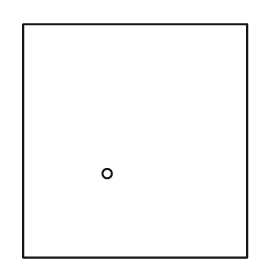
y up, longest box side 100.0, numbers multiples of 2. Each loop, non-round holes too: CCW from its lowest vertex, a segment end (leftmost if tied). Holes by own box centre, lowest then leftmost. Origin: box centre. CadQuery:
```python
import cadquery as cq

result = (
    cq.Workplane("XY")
    .moveTo(-48.0, -50.0)
    .lineTo(48.0, -50.0)
    .lineTo(48.0, 50.0)
    .lineTo(-48.0, 50.0)
    .close()
    .moveTo(-12.0, -14.0)
    .circle(2.0)
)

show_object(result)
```